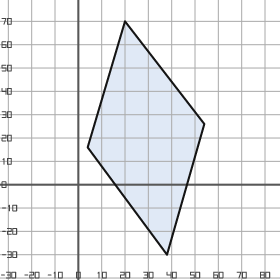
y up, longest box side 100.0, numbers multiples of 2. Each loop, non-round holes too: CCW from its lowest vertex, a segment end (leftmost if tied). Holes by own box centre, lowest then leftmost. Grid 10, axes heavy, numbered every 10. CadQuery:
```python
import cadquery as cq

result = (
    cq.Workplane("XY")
    .moveTo(38.0, -30.0)
    .lineTo(54.0, 26.0)
    .lineTo(20.0, 70.0)
    .lineTo(4.0, 16.0)
    .close()
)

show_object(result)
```